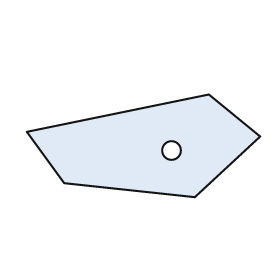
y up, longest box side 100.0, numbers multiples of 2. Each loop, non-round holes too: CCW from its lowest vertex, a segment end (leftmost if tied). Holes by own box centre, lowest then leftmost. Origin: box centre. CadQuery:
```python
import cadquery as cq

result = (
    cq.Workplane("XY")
    .moveTo(22.0, -22.0)
    .lineTo(50.0, 4.0)
    .lineTo(28.0, 22.0)
    .lineTo(-50.0, 6.0)
    .lineTo(-34.0, -16.0)
    .close()
    .moveTo(12.0, -2.0)
    .circle(4.0)
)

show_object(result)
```